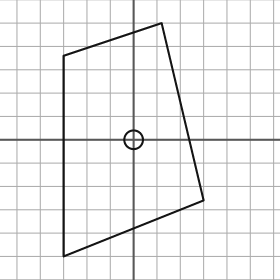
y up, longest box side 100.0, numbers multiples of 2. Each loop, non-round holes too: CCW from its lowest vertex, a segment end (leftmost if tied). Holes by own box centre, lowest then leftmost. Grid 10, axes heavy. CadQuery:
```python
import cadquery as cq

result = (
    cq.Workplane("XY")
    .moveTo(-30.0, -50.0)
    .lineTo(30.0, -26.0)
    .lineTo(12.0, 50.0)
    .lineTo(-30.0, 36.0)
    .close()
    .moveTo(0.0, 0.0)
    .circle(4.0)
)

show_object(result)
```